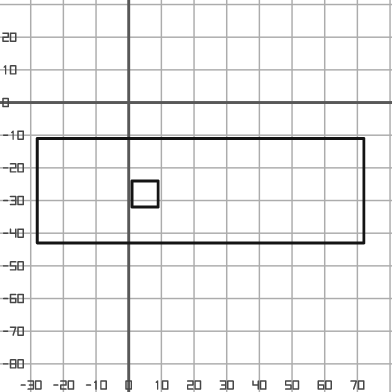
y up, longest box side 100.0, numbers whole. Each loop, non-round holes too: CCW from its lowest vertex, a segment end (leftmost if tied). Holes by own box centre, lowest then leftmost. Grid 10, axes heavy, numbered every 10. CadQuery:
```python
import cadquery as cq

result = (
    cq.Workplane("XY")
    .moveTo(-28.0, -43.0)
    .lineTo(72.0, -43.0)
    .lineTo(72.0, -11.0)
    .lineTo(-28.0, -11.0)
    .close()
    .moveTo(1.0, -32.0)
    .lineTo(9.0, -32.0)
    .lineTo(9.0, -24.0)
    .lineTo(1.0, -24.0)
    .close()
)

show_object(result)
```